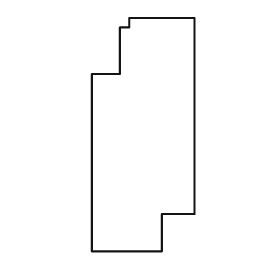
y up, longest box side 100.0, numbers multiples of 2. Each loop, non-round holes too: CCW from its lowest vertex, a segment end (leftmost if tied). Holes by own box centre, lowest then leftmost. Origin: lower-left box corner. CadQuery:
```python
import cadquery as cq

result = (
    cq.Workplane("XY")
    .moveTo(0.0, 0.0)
    .lineTo(30.0, 0.0)
    .lineTo(30.0, 16.0)
    .lineTo(44.0, 16.0)
    .lineTo(44.0, 100.0)
    .lineTo(16.0, 100.0)
    .lineTo(16.0, 96.0)
    .lineTo(12.0, 96.0)
    .lineTo(12.0, 76.0)
    .lineTo(0.0, 76.0)
    .close()
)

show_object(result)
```